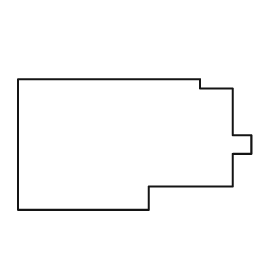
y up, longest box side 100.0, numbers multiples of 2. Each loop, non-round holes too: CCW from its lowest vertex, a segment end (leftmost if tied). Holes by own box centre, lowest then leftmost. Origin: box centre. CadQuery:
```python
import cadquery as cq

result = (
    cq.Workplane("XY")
    .moveTo(-50.0, -28.0)
    .lineTo(6.0, -28.0)
    .lineTo(6.0, -18.0)
    .lineTo(42.0, -18.0)
    .lineTo(42.0, -4.0)
    .lineTo(50.0, -4.0)
    .lineTo(50.0, 4.0)
    .lineTo(42.0, 4.0)
    .lineTo(42.0, 24.0)
    .lineTo(28.0, 24.0)
    .lineTo(28.0, 28.0)
    .lineTo(-50.0, 28.0)
    .close()
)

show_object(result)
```